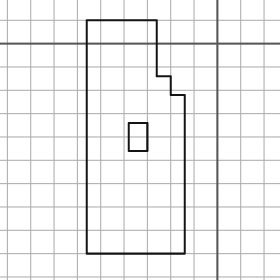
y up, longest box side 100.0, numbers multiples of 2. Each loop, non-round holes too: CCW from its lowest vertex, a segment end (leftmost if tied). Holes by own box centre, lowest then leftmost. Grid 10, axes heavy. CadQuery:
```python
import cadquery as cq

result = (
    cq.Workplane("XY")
    .moveTo(-56.0, -90.0)
    .lineTo(-14.0, -90.0)
    .lineTo(-14.0, -22.0)
    .lineTo(-20.0, -22.0)
    .lineTo(-20.0, -14.0)
    .lineTo(-26.0, -14.0)
    .lineTo(-26.0, 10.0)
    .lineTo(-56.0, 10.0)
    .close()
    .moveTo(-38.0, -46.0)
    .lineTo(-30.0, -46.0)
    .lineTo(-30.0, -34.0)
    .lineTo(-38.0, -34.0)
    .close()
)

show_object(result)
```